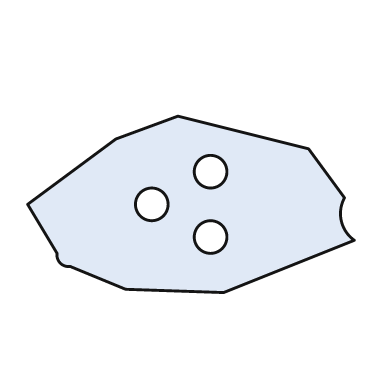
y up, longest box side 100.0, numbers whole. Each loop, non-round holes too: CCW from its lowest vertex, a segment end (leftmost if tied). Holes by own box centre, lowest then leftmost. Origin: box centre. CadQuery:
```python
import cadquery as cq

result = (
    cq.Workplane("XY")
    .moveTo(10.0, -27.0)
    .lineTo(50.0, -11.0)
    .threePointArc((46.0, -5.0), (47.0, 2.0))
    .lineTo(36.0, 17.0)
    .lineTo(-4.0, 27.0)
    .lineTo(-23.0, 20.0)
    .lineTo(-50.0, 0.0)
    .lineTo(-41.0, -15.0)
    .threePointArc((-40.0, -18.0), (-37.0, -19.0))
    .lineTo(-20.0, -26.0)
    .close()
    .moveTo(6.0, -10.0)
    .circle(5.0)
    .moveTo(-12.0, 0.0)
    .circle(5.0)
    .moveTo(6.0, 10.0)
    .circle(5.0)
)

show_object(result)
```